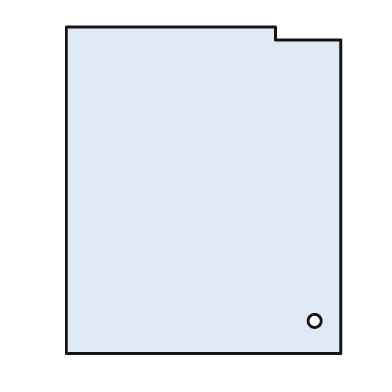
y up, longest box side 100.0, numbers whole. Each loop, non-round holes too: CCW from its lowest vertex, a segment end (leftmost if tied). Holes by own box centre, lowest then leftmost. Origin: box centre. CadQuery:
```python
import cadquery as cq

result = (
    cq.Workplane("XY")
    .moveTo(-42.0, -50.0)
    .lineTo(42.0, -50.0)
    .lineTo(42.0, 46.0)
    .lineTo(22.0, 46.0)
    .lineTo(22.0, 50.0)
    .lineTo(-42.0, 50.0)
    .close()
    .moveTo(34.0, -40.0)
    .circle(2.0)
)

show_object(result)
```